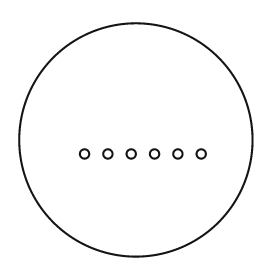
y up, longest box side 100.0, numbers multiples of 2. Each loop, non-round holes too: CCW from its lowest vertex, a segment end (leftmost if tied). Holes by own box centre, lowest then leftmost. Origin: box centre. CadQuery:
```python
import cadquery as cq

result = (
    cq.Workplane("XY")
    .moveTo(0.0, 0.0)
    .circle(50.0)
    .moveTo(-22.0, -6.0)
    .circle(2.0)
    .moveTo(-12.0, -6.0)
    .circle(2.0)
    .moveTo(-2.0, -6.0)
    .circle(2.0)
    .moveTo(8.0, -6.0)
    .circle(2.0)
    .moveTo(18.0, -6.0)
    .circle(2.0)
    .moveTo(28.0, -6.0)
    .circle(2.0)
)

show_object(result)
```